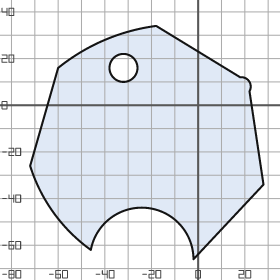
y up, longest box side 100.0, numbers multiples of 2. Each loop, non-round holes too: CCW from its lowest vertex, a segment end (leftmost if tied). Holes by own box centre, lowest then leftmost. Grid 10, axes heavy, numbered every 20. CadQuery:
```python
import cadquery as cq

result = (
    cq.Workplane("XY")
    .moveTo(-2.0, -66.0)
    .lineTo(28.0, -34.0)
    .lineTo(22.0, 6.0)
    .threePointArc((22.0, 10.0), (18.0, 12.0))
    .lineTo(-18.0, 34.0)
    .threePointArc((-40.0, 28.0), (-60.0, 16.0))
    .lineTo(-72.0, -26.0)
    .threePointArc((-62.0, -46.0), (-46.0, -62.0))
    .threePointArc((-22.0, -44.0), (-2.0, -66.0))
    .close()
    .moveTo(-32.0, 16.0)
    .circle(6.0)
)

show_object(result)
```